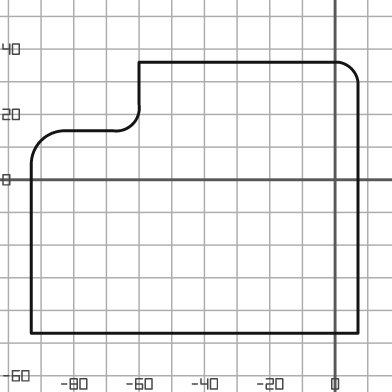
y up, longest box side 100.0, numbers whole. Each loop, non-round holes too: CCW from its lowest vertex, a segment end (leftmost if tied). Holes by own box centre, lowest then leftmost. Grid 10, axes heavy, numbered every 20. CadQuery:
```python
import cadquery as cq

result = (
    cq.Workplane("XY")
    .moveTo(-93.0, -47.0)
    .lineTo(7.0, -47.0)
    .lineTo(7.0, 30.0)
    .threePointArc((5.0, 34.0), (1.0, 36.0))
    .lineTo(-60.0, 36.0)
    .lineTo(-60.0, 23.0)
    .threePointArc((-62.0, 17.0), (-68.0, 15.0))
    .lineTo(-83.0, 15.0)
    .threePointArc((-90.0, 12.0), (-93.0, 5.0))
    .close()
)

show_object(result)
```